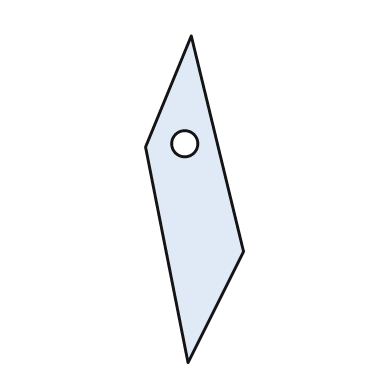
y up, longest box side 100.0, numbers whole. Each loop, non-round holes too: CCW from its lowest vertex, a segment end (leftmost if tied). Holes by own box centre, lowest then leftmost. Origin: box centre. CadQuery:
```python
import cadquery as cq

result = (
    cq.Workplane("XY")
    .moveTo(-2.0, -50.0)
    .lineTo(15.0, -16.0)
    .lineTo(-1.0, 50.0)
    .lineTo(-15.0, 16.0)
    .close()
    .moveTo(-3.0, 17.0)
    .circle(4.0)
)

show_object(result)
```